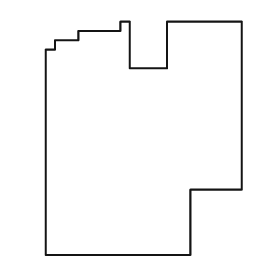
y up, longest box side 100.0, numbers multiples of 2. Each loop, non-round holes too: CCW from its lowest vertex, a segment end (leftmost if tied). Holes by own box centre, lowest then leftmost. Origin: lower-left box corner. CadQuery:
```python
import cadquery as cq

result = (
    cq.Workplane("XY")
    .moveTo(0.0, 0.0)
    .lineTo(62.0, 0.0)
    .lineTo(62.0, 28.0)
    .lineTo(84.0, 28.0)
    .lineTo(84.0, 100.0)
    .lineTo(52.0, 100.0)
    .lineTo(52.0, 80.0)
    .lineTo(36.0, 80.0)
    .lineTo(36.0, 100.0)
    .lineTo(32.0, 100.0)
    .lineTo(32.0, 96.0)
    .lineTo(14.0, 96.0)
    .lineTo(14.0, 92.0)
    .lineTo(4.0, 92.0)
    .lineTo(4.0, 88.0)
    .lineTo(0.0, 88.0)
    .close()
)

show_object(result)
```